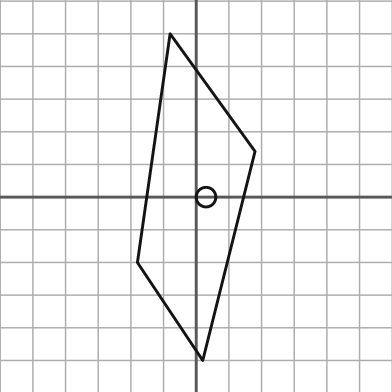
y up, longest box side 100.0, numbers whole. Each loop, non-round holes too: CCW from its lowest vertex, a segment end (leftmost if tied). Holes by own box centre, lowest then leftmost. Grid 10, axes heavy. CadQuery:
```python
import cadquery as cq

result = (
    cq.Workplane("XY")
    .moveTo(2.0, -50.0)
    .lineTo(18.0, 14.0)
    .lineTo(-8.0, 50.0)
    .lineTo(-18.0, -20.0)
    .close()
    .moveTo(3.0, 0.0)
    .circle(3.0)
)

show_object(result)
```